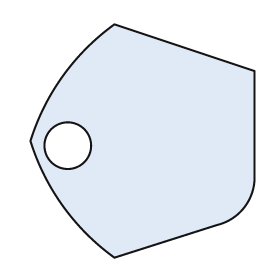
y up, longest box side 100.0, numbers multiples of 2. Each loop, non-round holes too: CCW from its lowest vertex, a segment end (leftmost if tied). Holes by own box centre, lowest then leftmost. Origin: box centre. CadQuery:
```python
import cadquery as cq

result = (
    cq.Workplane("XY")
    .moveTo(-12.0, -50.0)
    .lineTo(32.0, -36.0)
    .threePointArc((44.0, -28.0), (48.0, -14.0))
    .lineTo(48.0, 30.0)
    .lineTo(-12.0, 50.0)
    .threePointArc((-34.0, 28.0), (-48.0, 0.0))
    .threePointArc((-34.0, -28.0), (-12.0, -50.0))
    .close()
    .moveTo(-32.0, -2.0)
    .circle(10.0)
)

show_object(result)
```